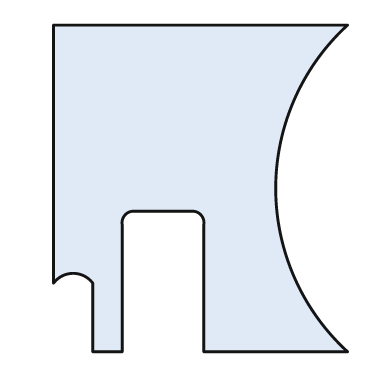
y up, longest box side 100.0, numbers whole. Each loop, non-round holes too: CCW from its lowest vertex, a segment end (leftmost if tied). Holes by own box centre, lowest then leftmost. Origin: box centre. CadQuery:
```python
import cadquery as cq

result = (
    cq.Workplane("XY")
    .moveTo(-33.0, -50.0)
    .lineTo(-24.0, -50.0)
    .lineTo(-24.0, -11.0)
    .threePointArc((-23.0, -8.0), (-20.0, -7.0))
    .lineTo(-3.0, -7.0)
    .threePointArc((0.0, -8.0), (1.0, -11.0))
    .lineTo(1.0, -50.0)
    .lineTo(45.0, -50.0)
    .threePointArc((23.0, 0.0), (45.0, 50.0))
    .lineTo(-45.0, 50.0)
    .lineTo(-45.0, -29.0)
    .threePointArc((-39.0, -26.0), (-33.0, -29.0))
    .close()
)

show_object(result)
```